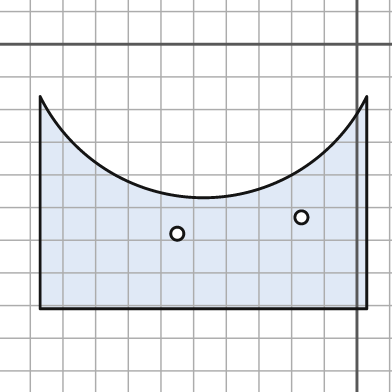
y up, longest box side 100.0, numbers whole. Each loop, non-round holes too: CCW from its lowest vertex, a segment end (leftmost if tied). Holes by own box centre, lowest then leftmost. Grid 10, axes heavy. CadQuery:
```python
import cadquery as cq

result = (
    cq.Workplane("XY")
    .moveTo(-97.0, -81.0)
    .lineTo(3.0, -81.0)
    .lineTo(3.0, -16.0)
    .threePointArc((-47.0, -47.0), (-97.0, -16.0))
    .close()
    .moveTo(-55.0, -58.0)
    .circle(2.0)
    .moveTo(-17.0, -53.0)
    .circle(2.0)
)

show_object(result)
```